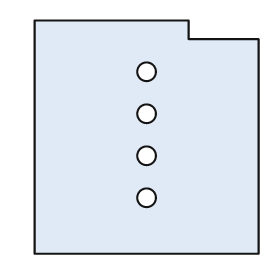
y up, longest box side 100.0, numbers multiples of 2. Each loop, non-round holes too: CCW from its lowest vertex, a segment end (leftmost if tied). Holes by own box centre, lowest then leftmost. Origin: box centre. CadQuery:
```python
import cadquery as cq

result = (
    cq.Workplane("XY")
    .moveTo(-48.0, -50.0)
    .lineTo(48.0, -50.0)
    .lineTo(48.0, 42.0)
    .lineTo(18.0, 42.0)
    .lineTo(18.0, 50.0)
    .lineTo(-48.0, 50.0)
    .close()
    .moveTo(0.0, -26.0)
    .circle(4.0)
    .moveTo(0.0, -8.0)
    .circle(4.0)
    .moveTo(0.0, 10.0)
    .circle(4.0)
    .moveTo(0.0, 28.0)
    .circle(4.0)
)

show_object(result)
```